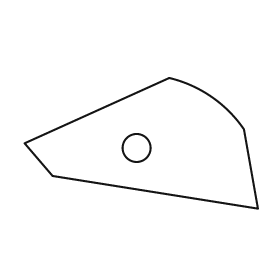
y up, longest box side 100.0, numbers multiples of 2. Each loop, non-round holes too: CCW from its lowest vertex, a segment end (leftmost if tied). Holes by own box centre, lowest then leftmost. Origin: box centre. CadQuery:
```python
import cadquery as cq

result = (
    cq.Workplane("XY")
    .moveTo(50.0, -28.0)
    .lineTo(44.0, 6.0)
    .threePointArc((30.0, 20.0), (12.0, 28.0))
    .lineTo(-50.0, 0.0)
    .lineTo(-38.0, -14.0)
    .close()
    .moveTo(-2.0, -2.0)
    .circle(6.0)
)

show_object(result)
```